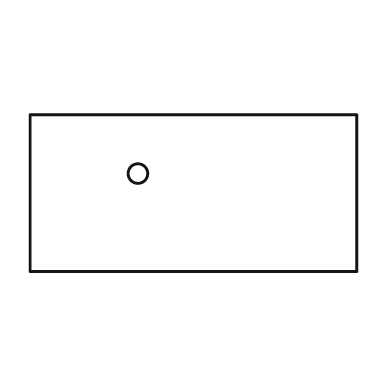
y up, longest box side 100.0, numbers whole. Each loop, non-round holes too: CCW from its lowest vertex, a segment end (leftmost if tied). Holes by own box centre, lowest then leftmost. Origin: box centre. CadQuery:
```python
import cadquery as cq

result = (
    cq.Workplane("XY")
    .moveTo(-50.0, -24.0)
    .lineTo(50.0, -24.0)
    .lineTo(50.0, 24.0)
    .lineTo(-50.0, 24.0)
    .close()
    .moveTo(-17.0, 6.0)
    .circle(3.0)
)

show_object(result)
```